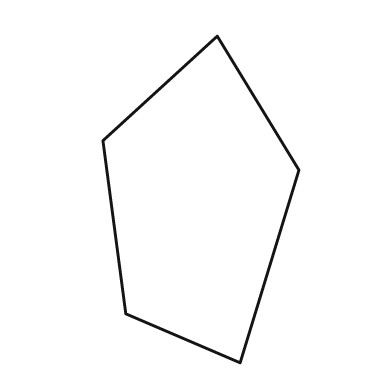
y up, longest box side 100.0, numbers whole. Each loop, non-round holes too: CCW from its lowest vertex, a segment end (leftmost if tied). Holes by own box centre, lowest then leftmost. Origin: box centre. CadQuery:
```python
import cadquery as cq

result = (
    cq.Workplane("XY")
    .moveTo(12.0, -50.0)
    .lineTo(30.0, 9.0)
    .lineTo(5.0, 50.0)
    .lineTo(-30.0, 18.0)
    .lineTo(-23.0, -35.0)
    .close()
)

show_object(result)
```